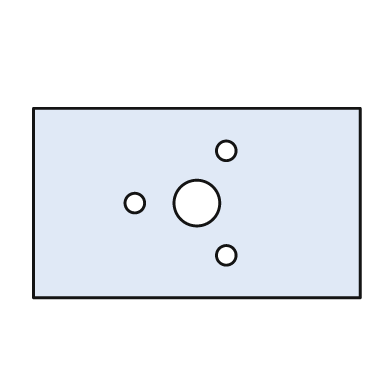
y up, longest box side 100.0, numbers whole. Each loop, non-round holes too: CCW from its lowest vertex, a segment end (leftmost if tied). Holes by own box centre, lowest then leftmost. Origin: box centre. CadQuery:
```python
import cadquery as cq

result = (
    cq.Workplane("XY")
    .moveTo(-50.0, -29.0)
    .lineTo(50.0, -29.0)
    .lineTo(50.0, 29.0)
    .lineTo(-50.0, 29.0)
    .close()
    .moveTo(9.0, -16.0)
    .circle(3.0)
    .moveTo(-19.0, 0.0)
    .circle(3.0)
    .moveTo(0.0, 0.0)
    .circle(7.0)
    .moveTo(9.0, 16.0)
    .circle(3.0)
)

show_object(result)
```